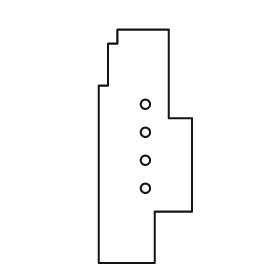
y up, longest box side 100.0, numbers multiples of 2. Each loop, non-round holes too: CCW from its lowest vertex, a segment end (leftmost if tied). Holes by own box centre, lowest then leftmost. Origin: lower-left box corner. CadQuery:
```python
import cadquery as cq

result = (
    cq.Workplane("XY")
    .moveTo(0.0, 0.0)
    .lineTo(24.0, 0.0)
    .lineTo(24.0, 22.0)
    .lineTo(40.0, 22.0)
    .lineTo(40.0, 62.0)
    .lineTo(30.0, 62.0)
    .lineTo(30.0, 100.0)
    .lineTo(8.0, 100.0)
    .lineTo(8.0, 94.0)
    .lineTo(4.0, 94.0)
    .lineTo(4.0, 76.0)
    .lineTo(0.0, 76.0)
    .close()
    .moveTo(20.0, 32.0)
    .circle(2.0)
    .moveTo(20.0, 44.0)
    .circle(2.0)
    .moveTo(20.0, 56.0)
    .circle(2.0)
    .moveTo(20.0, 68.0)
    .circle(2.0)
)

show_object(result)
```